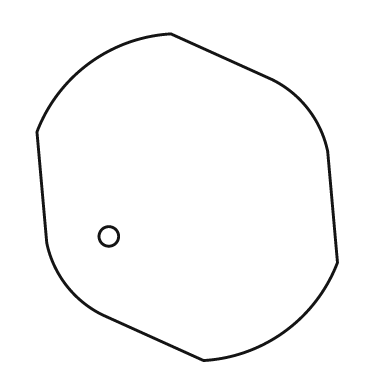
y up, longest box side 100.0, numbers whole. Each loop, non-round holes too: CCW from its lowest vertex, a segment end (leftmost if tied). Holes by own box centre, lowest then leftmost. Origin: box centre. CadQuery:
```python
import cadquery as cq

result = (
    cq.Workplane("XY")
    .moveTo(5.0, -50.0)
    .threePointArc((30.0, -41.0), (46.0, -20.0))
    .lineTo(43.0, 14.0)
    .threePointArc((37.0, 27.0), (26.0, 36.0))
    .lineTo(-5.0, 50.0)
    .threePointArc((-30.0, 41.0), (-46.0, 20.0))
    .lineTo(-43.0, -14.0)
    .threePointArc((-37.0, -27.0), (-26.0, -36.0))
    .close()
    .moveTo(-24.0, -12.0)
    .circle(3.0)
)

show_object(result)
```